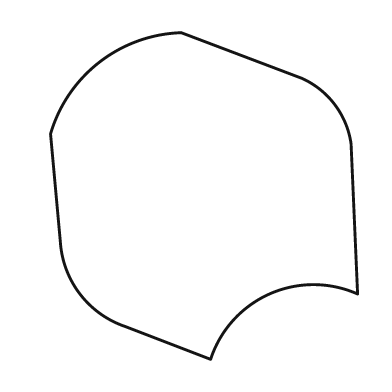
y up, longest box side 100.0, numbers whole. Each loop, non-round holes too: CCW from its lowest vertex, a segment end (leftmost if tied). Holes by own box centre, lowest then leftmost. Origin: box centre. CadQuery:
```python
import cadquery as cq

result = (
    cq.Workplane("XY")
    .moveTo(2.0, -50.0)
    .threePointArc((20.0, -30.0), (47.0, -30.0))
    .lineTo(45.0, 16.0)
    .threePointArc((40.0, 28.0), (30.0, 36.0))
    .lineTo(-7.0, 50.0)
    .threePointArc((-32.0, 41.0), (-47.0, 19.0))
    .lineTo(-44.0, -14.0)
    .threePointArc((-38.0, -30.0), (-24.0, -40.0))
    .close()
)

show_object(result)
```